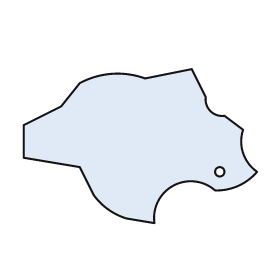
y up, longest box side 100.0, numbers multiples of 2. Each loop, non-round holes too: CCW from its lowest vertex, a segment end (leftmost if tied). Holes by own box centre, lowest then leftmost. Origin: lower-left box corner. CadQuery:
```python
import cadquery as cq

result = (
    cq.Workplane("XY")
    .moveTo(56.0, 0.0)
    .threePointArc((64.0, 16.0), (82.0, 14.0))
    .threePointArc((92.0, 16.0), (100.0, 22.0))
    .threePointArc((94.0, 30.0), (94.0, 40.0))
    .lineTo(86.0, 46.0)
    .threePointArc((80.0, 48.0), (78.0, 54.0))
    .lineTo(72.0, 66.0)
    .lineTo(52.0, 62.0)
    .threePointArc((38.0, 64.0), (24.0, 60.0))
    .lineTo(16.0, 50.0)
    .lineTo(0.0, 42.0)
    .lineTo(0.0, 28.0)
    .lineTo(24.0, 24.0)
    .lineTo(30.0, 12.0)
    .threePointArc((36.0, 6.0), (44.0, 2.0))
    .close()
    .moveTo(84.0, 22.0)
    .circle(2.0)
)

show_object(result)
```